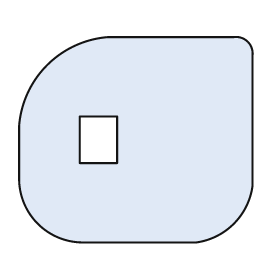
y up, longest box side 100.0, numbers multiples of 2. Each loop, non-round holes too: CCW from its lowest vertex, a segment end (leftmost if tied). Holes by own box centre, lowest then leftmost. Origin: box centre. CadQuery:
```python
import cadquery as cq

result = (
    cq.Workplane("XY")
    .moveTo(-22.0, -44.0)
    .lineTo(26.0, -44.0)
    .threePointArc((42.0, -36.0), (50.0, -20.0))
    .lineTo(50.0, 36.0)
    .threePointArc((48.0, 42.0), (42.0, 44.0))
    .lineTo(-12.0, 44.0)
    .threePointArc((-38.0, 32.0), (-50.0, 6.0))
    .lineTo(-50.0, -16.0)
    .threePointArc((-42.0, -36.0), (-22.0, -44.0))
    .close()
    .moveTo(-24.0, -10.0)
    .lineTo(-8.0, -10.0)
    .lineTo(-8.0, 10.0)
    .lineTo(-24.0, 10.0)
    .close()
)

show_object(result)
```